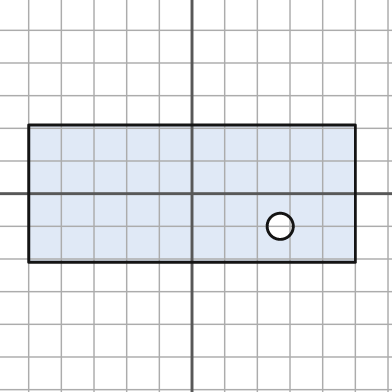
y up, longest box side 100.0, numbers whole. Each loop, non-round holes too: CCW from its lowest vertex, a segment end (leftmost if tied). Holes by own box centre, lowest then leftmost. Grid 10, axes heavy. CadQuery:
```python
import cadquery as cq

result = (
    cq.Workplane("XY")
    .moveTo(-50.0, -21.0)
    .lineTo(50.0, -21.0)
    .lineTo(50.0, 21.0)
    .lineTo(-50.0, 21.0)
    .close()
    .moveTo(27.0, -10.0)
    .circle(4.0)
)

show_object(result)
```